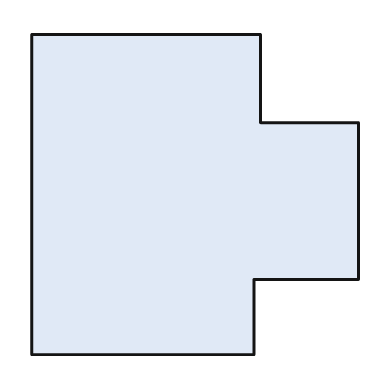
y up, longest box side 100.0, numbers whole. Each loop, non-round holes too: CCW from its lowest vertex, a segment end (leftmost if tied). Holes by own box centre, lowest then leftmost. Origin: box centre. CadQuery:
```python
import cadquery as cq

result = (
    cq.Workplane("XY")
    .moveTo(-50.0, -49.0)
    .lineTo(18.0, -49.0)
    .lineTo(18.0, -26.0)
    .lineTo(50.0, -26.0)
    .lineTo(50.0, 22.0)
    .lineTo(20.0, 22.0)
    .lineTo(20.0, 49.0)
    .lineTo(-50.0, 49.0)
    .close()
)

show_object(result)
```